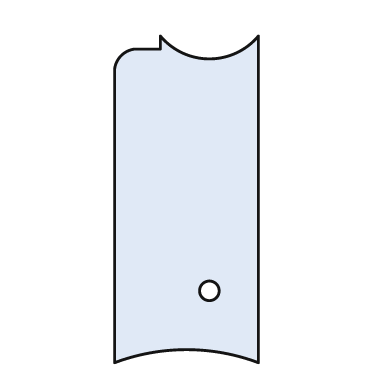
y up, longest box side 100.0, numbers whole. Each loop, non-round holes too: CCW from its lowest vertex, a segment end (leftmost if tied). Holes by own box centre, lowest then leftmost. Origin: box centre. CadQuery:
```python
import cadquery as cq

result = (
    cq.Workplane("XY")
    .moveTo(-22.0, -50.0)
    .threePointArc((0.0, -46.0), (22.0, -50.0))
    .lineTo(22.0, 50.0)
    .threePointArc((7.0, 43.0), (-8.0, 50.0))
    .lineTo(-8.0, 46.0)
    .lineTo(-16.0, 46.0)
    .threePointArc((-20.0, 44.0), (-22.0, 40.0))
    .close()
    .moveTo(7.0, -28.0)
    .circle(3.0)
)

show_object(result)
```